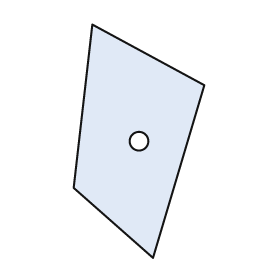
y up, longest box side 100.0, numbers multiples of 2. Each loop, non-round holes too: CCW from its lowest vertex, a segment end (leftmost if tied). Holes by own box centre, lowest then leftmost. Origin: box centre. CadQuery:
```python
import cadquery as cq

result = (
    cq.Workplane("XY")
    .moveTo(6.0, -50.0)
    .lineTo(28.0, 24.0)
    .lineTo(-20.0, 50.0)
    .lineTo(-28.0, -20.0)
    .close()
    .moveTo(0.0, 0.0)
    .circle(4.0)
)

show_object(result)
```